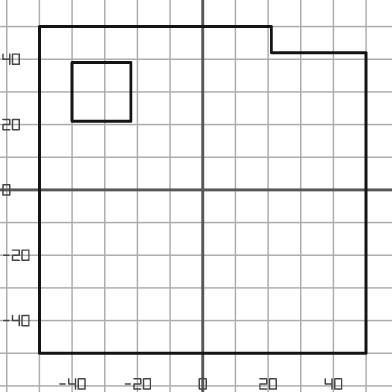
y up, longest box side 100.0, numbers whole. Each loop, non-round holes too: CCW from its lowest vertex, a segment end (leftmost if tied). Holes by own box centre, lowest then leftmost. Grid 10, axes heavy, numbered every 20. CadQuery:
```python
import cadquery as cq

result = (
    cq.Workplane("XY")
    .moveTo(-50.0, -50.0)
    .lineTo(50.0, -50.0)
    .lineTo(50.0, 42.0)
    .lineTo(21.0, 42.0)
    .lineTo(21.0, 50.0)
    .lineTo(-50.0, 50.0)
    .close()
    .moveTo(-40.0, 21.0)
    .lineTo(-22.0, 21.0)
    .lineTo(-22.0, 39.0)
    .lineTo(-40.0, 39.0)
    .close()
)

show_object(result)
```